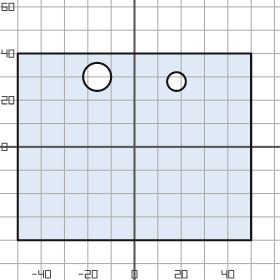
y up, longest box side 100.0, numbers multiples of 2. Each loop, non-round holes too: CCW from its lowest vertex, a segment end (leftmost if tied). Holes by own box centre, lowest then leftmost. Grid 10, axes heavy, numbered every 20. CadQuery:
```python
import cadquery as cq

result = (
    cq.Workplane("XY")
    .moveTo(-50.0, -40.0)
    .lineTo(50.0, -40.0)
    .lineTo(50.0, 40.0)
    .lineTo(-50.0, 40.0)
    .close()
    .moveTo(18.0, 28.0)
    .circle(4.0)
    .moveTo(-16.0, 30.0)
    .circle(6.0)
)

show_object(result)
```